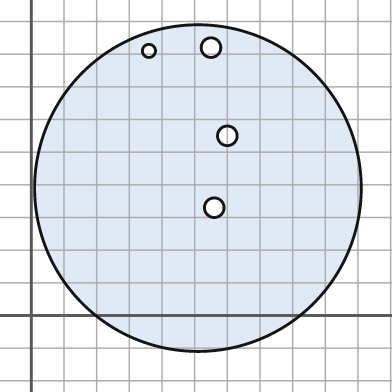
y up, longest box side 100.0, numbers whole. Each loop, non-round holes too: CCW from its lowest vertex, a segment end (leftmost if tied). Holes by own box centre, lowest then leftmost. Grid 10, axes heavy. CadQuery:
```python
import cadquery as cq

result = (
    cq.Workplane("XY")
    .moveTo(51.0, 39.0)
    .circle(50.0)
    .moveTo(56.0, 33.0)
    .circle(3.0)
    .moveTo(60.0, 55.0)
    .circle(3.0)
    .moveTo(36.0, 81.0)
    .circle(2.0)
    .moveTo(55.0, 82.0)
    .circle(3.0)
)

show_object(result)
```